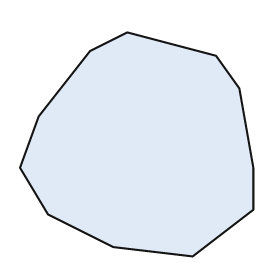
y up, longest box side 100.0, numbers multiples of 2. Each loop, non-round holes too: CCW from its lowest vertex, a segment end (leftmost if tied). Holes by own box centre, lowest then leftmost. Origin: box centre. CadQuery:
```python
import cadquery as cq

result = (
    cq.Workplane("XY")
    .moveTo(24.0, -48.0)
    .lineTo(50.0, -28.0)
    .lineTo(50.0, -10.0)
    .lineTo(44.0, 24.0)
    .lineTo(34.0, 38.0)
    .lineTo(-4.0, 48.0)
    .lineTo(-20.0, 40.0)
    .lineTo(-42.0, 12.0)
    .lineTo(-50.0, -10.0)
    .lineTo(-38.0, -30.0)
    .lineTo(-10.0, -44.0)
    .close()
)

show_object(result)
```